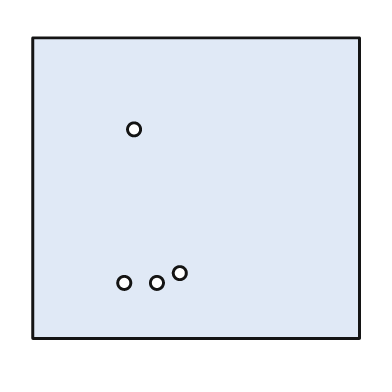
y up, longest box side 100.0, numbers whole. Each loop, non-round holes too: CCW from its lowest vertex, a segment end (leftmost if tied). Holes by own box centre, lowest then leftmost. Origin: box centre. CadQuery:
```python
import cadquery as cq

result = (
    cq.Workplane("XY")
    .moveTo(-50.0, -46.0)
    .lineTo(50.0, -46.0)
    .lineTo(50.0, 46.0)
    .lineTo(-50.0, 46.0)
    .close()
    .moveTo(-22.0, -29.0)
    .circle(2.0)
    .moveTo(-12.0, -29.0)
    .circle(2.0)
    .moveTo(-5.0, -26.0)
    .circle(2.0)
    .moveTo(-19.0, 18.0)
    .circle(2.0)
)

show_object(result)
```